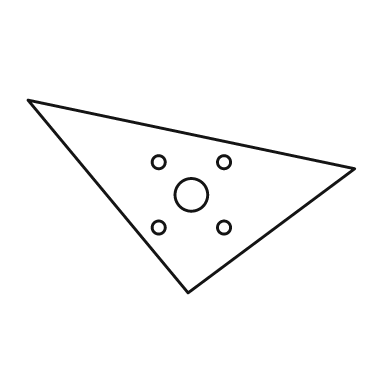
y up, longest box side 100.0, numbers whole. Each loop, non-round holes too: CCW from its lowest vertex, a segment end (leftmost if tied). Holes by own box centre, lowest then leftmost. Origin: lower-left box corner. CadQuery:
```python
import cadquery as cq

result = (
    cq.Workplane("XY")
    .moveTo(49.0, 0.0)
    .lineTo(100.0, 38.0)
    .lineTo(0.0, 59.0)
    .close()
    .moveTo(40.0, 20.0)
    .circle(2.0)
    .moveTo(60.0, 20.0)
    .circle(2.0)
    .moveTo(50.0, 30.0)
    .circle(5.0)
    .moveTo(40.0, 40.0)
    .circle(2.0)
    .moveTo(60.0, 40.0)
    .circle(2.0)
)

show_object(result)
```